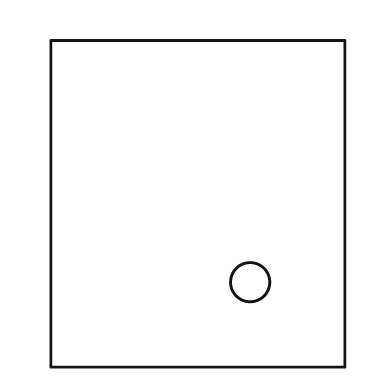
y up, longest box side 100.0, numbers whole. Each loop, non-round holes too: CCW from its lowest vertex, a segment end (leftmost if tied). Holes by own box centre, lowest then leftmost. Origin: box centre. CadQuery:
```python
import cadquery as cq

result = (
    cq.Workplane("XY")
    .moveTo(-45.0, -50.0)
    .lineTo(45.0, -50.0)
    .lineTo(45.0, 50.0)
    .lineTo(-45.0, 50.0)
    .close()
    .moveTo(16.0, -24.0)
    .circle(6.0)
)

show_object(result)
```